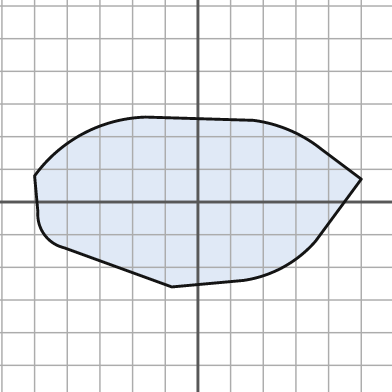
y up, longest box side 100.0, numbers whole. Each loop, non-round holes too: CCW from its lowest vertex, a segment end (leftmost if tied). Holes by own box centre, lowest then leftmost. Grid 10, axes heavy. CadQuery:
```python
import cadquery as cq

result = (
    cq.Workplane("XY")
    .moveTo(-8.0, -26.0)
    .lineTo(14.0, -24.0)
    .threePointArc((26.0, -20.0), (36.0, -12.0))
    .lineTo(50.0, 7.0)
    .lineTo(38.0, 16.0)
    .threePointArc((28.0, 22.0), (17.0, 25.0))
    .lineTo(-16.0, 26.0)
    .threePointArc((-35.0, 21.0), (-50.0, 8.0))
    .lineTo(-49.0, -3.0)
    .threePointArc((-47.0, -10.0), (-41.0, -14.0))
    .close()
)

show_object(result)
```